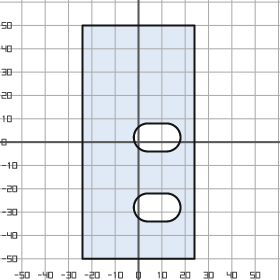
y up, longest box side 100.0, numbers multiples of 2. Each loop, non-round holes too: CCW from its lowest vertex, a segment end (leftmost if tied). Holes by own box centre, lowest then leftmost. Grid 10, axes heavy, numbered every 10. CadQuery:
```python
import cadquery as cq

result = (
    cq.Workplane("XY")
    .moveTo(-24.0, -50.0)
    .lineTo(24.0, -50.0)
    .lineTo(24.0, 50.0)
    .lineTo(-24.0, 50.0)
    .close()
    .moveTo(4.0, -34.0)
    .lineTo(12.0, -34.0)
    .threePointArc((18.0, -28.0), (12.0, -22.0))
    .lineTo(4.0, -22.0)
    .threePointArc((-2.0, -28.0), (4.0, -34.0))
    .close()
    .moveTo(4.0, -4.0)
    .lineTo(12.0, -4.0)
    .threePointArc((18.0, 2.0), (12.0, 8.0))
    .lineTo(4.0, 8.0)
    .threePointArc((-2.0, 2.0), (4.0, -4.0))
    .close()
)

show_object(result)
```